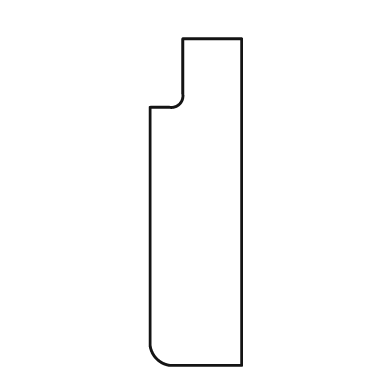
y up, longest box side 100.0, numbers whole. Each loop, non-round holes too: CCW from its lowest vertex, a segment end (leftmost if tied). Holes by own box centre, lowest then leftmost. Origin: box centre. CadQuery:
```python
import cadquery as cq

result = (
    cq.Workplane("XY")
    .moveTo(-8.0, -50.0)
    .lineTo(14.0, -50.0)
    .lineTo(14.0, 50.0)
    .lineTo(-4.0, 50.0)
    .lineTo(-4.0, 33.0)
    .threePointArc((-5.0, 30.0), (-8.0, 29.0))
    .lineTo(-14.0, 29.0)
    .lineTo(-14.0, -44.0)
    .threePointArc((-12.0, -48.0), (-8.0, -50.0))
    .close()
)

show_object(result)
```